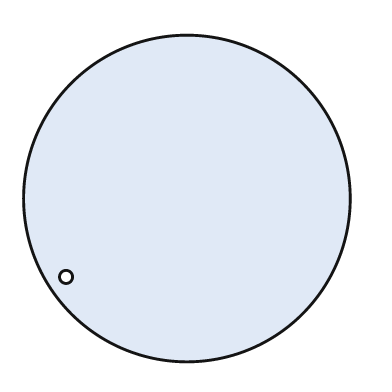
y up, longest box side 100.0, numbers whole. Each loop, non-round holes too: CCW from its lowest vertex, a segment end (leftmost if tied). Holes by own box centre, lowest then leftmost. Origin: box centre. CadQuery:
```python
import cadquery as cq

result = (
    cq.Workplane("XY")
    .moveTo(0.0, 0.0)
    .circle(50.0)
    .moveTo(-37.0, -24.0)
    .circle(2.0)
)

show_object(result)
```